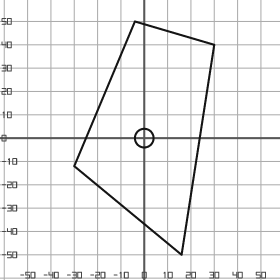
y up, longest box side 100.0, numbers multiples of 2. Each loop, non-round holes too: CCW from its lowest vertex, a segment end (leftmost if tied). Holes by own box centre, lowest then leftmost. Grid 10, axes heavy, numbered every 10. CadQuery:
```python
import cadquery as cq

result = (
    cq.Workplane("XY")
    .moveTo(16.0, -50.0)
    .lineTo(30.0, 40.0)
    .lineTo(-4.0, 50.0)
    .lineTo(-30.0, -12.0)
    .close()
    .moveTo(0.0, 0.0)
    .circle(4.0)
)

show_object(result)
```